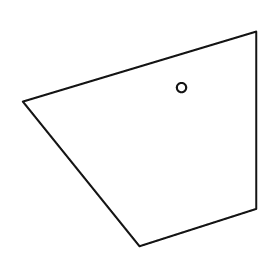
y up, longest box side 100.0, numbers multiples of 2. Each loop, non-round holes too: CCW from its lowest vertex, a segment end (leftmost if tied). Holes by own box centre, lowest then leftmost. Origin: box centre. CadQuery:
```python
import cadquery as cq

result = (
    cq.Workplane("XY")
    .moveTo(0.0, -46.0)
    .lineTo(50.0, -30.0)
    .lineTo(50.0, 46.0)
    .lineTo(-50.0, 16.0)
    .close()
    .moveTo(18.0, 22.0)
    .circle(2.0)
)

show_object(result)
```